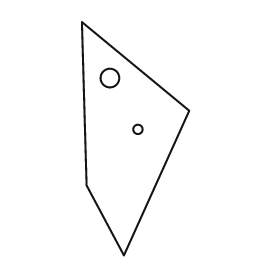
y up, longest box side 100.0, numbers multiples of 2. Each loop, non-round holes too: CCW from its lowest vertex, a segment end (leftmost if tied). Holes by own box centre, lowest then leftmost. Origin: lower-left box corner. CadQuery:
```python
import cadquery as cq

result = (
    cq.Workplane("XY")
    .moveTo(18.0, 0.0)
    .lineTo(46.0, 62.0)
    .lineTo(0.0, 100.0)
    .lineTo(2.0, 30.0)
    .close()
    .moveTo(24.0, 54.0)
    .circle(2.0)
    .moveTo(12.0, 76.0)
    .circle(4.0)
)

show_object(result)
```